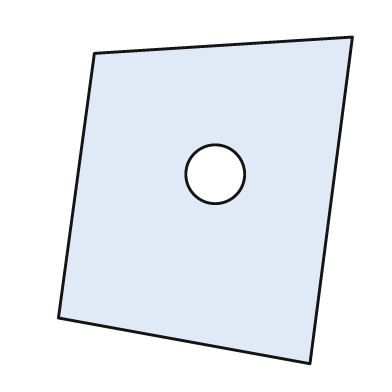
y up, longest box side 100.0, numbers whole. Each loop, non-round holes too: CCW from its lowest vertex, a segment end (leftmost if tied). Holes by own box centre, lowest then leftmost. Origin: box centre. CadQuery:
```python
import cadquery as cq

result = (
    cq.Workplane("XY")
    .moveTo(32.0, -50.0)
    .lineTo(45.0, 50.0)
    .lineTo(-34.0, 45.0)
    .lineTo(-45.0, -36.0)
    .close()
    .moveTo(3.0, 8.0)
    .circle(9.0)
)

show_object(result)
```